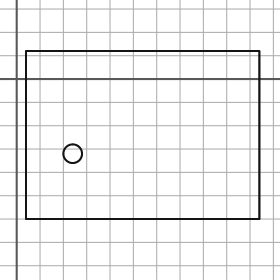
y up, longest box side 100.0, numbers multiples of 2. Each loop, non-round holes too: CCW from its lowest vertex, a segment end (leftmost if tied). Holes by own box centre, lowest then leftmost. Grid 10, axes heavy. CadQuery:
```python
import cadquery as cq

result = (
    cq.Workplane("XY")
    .moveTo(4.0, -60.0)
    .lineTo(104.0, -60.0)
    .lineTo(104.0, 12.0)
    .lineTo(4.0, 12.0)
    .close()
    .moveTo(24.0, -32.0)
    .circle(4.0)
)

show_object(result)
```